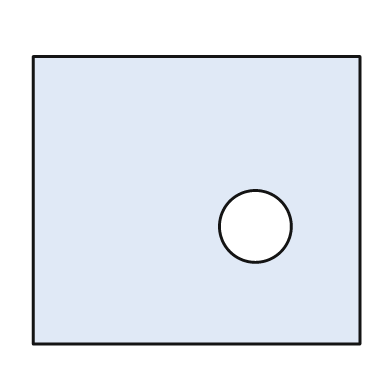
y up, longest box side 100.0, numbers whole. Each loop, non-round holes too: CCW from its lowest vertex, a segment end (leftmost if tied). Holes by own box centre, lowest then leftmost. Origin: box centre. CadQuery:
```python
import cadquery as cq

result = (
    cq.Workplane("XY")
    .moveTo(-50.0, -44.0)
    .lineTo(50.0, -44.0)
    .lineTo(50.0, 44.0)
    .lineTo(-50.0, 44.0)
    .close()
    .moveTo(18.0, -8.0)
    .circle(11.0)
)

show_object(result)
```